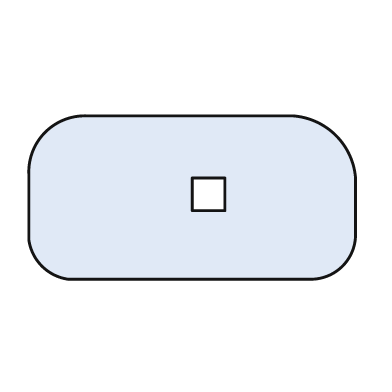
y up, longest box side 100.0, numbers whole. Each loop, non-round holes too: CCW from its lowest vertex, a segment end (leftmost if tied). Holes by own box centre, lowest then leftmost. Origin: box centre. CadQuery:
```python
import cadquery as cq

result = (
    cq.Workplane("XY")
    .moveTo(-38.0, -25.0)
    .lineTo(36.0, -25.0)
    .threePointArc((46.0, -21.0), (50.0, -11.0))
    .lineTo(50.0, 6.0)
    .threePointArc((44.0, 19.0), (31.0, 25.0))
    .lineTo(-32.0, 25.0)
    .threePointArc((-45.0, 20.0), (-50.0, 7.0))
    .lineTo(-50.0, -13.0)
    .threePointArc((-46.0, -21.0), (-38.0, -25.0))
    .close()
    .moveTo(0.0, -4.0)
    .lineTo(10.0, -4.0)
    .lineTo(10.0, 6.0)
    .lineTo(0.0, 6.0)
    .close()
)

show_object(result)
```